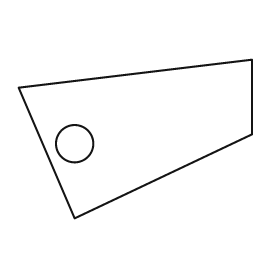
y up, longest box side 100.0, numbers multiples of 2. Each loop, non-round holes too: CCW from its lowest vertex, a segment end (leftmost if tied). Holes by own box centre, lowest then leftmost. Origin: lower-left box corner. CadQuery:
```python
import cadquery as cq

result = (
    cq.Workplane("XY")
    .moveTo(24.0, 0.0)
    .lineTo(100.0, 36.0)
    .lineTo(100.0, 68.0)
    .lineTo(0.0, 56.0)
    .close()
    .moveTo(24.0, 32.0)
    .circle(8.0)
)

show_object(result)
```